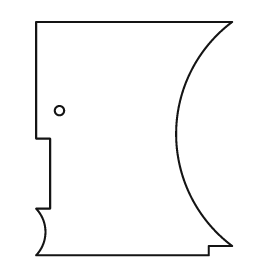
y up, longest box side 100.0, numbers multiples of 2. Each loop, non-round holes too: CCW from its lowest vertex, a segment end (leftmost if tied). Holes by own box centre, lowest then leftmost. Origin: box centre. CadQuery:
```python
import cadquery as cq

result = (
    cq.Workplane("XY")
    .moveTo(-42.0, -50.0)
    .lineTo(32.0, -50.0)
    .lineTo(32.0, -46.0)
    .lineTo(42.0, -46.0)
    .threePointArc((18.0, 2.0), (42.0, 50.0))
    .lineTo(-42.0, 50.0)
    .lineTo(-42.0, 0.0)
    .lineTo(-36.0, 0.0)
    .lineTo(-36.0, -30.0)
    .lineTo(-42.0, -30.0)
    .threePointArc((-38.0, -40.0), (-42.0, -50.0))
    .close()
    .moveTo(-32.0, 12.0)
    .circle(2.0)
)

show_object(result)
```